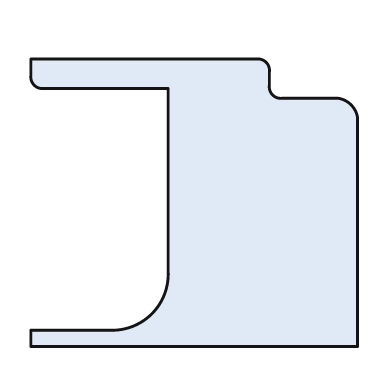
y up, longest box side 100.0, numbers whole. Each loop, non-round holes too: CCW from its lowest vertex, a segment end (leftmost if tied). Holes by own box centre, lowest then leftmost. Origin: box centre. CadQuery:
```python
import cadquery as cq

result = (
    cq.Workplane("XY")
    .moveTo(-50.0, -44.0)
    .lineTo(50.0, -44.0)
    .lineTo(50.0, 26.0)
    .threePointArc((48.0, 30.0), (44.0, 32.0))
    .lineTo(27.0, 32.0)
    .threePointArc((24.0, 33.0), (23.0, 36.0))
    .lineTo(23.0, 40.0)
    .threePointArc((22.0, 43.0), (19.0, 44.0))
    .lineTo(-50.0, 44.0)
    .lineTo(-50.0, 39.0)
    .threePointArc((-49.0, 36.0), (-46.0, 35.0))
    .lineTo(-8.0, 35.0)
    .lineTo(-8.0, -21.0)
    .threePointArc((-13.0, -34.0), (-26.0, -39.0))
    .lineTo(-50.0, -39.0)
    .close()
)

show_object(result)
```